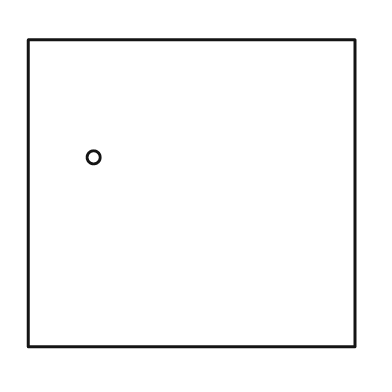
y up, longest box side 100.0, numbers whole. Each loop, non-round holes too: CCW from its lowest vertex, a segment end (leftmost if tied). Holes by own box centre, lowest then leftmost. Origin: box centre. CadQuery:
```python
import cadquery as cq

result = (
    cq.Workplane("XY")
    .moveTo(-50.0, -47.0)
    .lineTo(50.0, -47.0)
    .lineTo(50.0, 47.0)
    .lineTo(-50.0, 47.0)
    .close()
    .moveTo(-30.0, 11.0)
    .circle(2.0)
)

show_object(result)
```